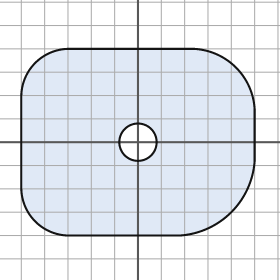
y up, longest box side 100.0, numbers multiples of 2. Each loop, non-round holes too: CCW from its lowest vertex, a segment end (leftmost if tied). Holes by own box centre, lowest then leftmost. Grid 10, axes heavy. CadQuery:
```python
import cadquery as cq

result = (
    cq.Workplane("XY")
    .moveTo(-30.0, -40.0)
    .lineTo(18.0, -40.0)
    .threePointArc((40.0, -30.0), (50.0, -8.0))
    .lineTo(50.0, 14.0)
    .threePointArc((42.0, 32.0), (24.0, 40.0))
    .lineTo(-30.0, 40.0)
    .threePointArc((-44.0, 34.0), (-50.0, 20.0))
    .lineTo(-50.0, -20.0)
    .threePointArc((-44.0, -34.0), (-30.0, -40.0))
    .close()
    .moveTo(0.0, 0.0)
    .circle(8.0)
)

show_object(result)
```